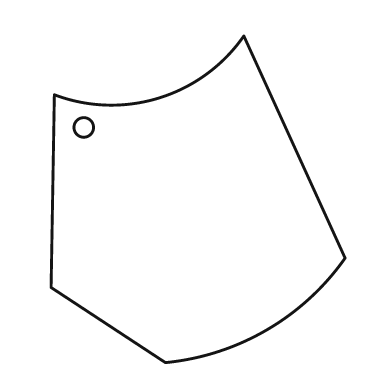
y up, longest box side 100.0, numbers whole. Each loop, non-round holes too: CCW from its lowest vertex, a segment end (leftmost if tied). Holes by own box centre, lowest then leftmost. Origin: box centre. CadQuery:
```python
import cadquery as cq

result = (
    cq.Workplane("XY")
    .moveTo(-10.0, -50.0)
    .threePointArc((21.0, -40.0), (45.0, -18.0))
    .lineTo(14.0, 50.0)
    .threePointArc((-12.0, 31.0), (-44.0, 32.0))
    .lineTo(-45.0, -27.0)
    .close()
    .moveTo(-35.0, 22.0)
    .circle(3.0)
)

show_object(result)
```